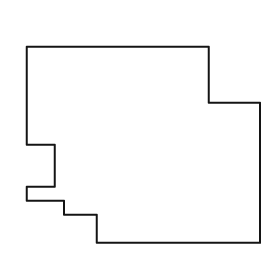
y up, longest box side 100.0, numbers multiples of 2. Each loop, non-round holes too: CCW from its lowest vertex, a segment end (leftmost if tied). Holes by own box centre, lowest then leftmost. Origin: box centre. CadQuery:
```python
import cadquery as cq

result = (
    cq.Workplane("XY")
    .moveTo(-20.0, -42.0)
    .lineTo(50.0, -42.0)
    .lineTo(50.0, 18.0)
    .lineTo(28.0, 18.0)
    .lineTo(28.0, 42.0)
    .lineTo(-50.0, 42.0)
    .lineTo(-50.0, 0.0)
    .lineTo(-38.0, 0.0)
    .lineTo(-38.0, -18.0)
    .lineTo(-50.0, -18.0)
    .lineTo(-50.0, -24.0)
    .lineTo(-34.0, -24.0)
    .lineTo(-34.0, -30.0)
    .lineTo(-20.0, -30.0)
    .close()
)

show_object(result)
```